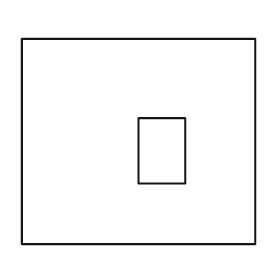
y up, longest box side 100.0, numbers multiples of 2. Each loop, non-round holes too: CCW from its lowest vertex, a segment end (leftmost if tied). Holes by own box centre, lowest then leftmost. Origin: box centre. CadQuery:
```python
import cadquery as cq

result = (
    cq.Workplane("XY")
    .moveTo(-50.0, -44.0)
    .lineTo(50.0, -44.0)
    .lineTo(50.0, 44.0)
    .lineTo(-50.0, 44.0)
    .close()
    .moveTo(0.0, -18.0)
    .lineTo(20.0, -18.0)
    .lineTo(20.0, 10.0)
    .lineTo(0.0, 10.0)
    .close()
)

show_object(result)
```